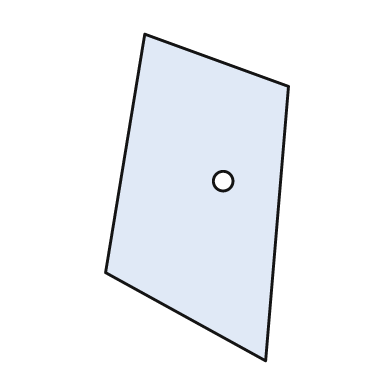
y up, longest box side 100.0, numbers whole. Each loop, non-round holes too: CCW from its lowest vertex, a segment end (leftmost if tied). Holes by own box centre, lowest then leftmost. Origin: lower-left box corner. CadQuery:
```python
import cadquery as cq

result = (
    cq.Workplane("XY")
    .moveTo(49.0, 0.0)
    .lineTo(56.0, 84.0)
    .lineTo(12.0, 100.0)
    .lineTo(0.0, 27.0)
    .close()
    .moveTo(36.0, 55.0)
    .circle(3.0)
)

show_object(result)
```